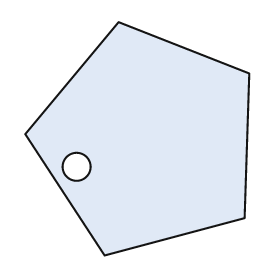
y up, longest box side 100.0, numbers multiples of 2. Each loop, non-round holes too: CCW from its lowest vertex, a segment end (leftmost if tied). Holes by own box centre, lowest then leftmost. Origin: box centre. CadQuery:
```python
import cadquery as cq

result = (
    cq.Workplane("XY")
    .moveTo(-14.0, -50.0)
    .lineTo(46.0, -34.0)
    .lineTo(48.0, 28.0)
    .lineTo(-8.0, 50.0)
    .lineTo(-48.0, 2.0)
    .close()
    .moveTo(-26.0, -12.0)
    .circle(6.0)
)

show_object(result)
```